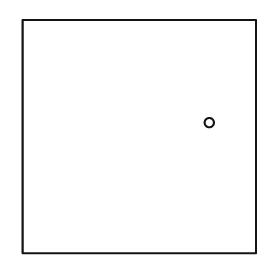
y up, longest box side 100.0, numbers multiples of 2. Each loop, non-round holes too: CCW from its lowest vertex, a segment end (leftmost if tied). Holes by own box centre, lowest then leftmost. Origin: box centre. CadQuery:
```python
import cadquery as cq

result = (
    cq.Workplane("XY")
    .moveTo(-50.0, -50.0)
    .lineTo(50.0, -50.0)
    .lineTo(50.0, 50.0)
    .lineTo(-50.0, 50.0)
    .close()
    .moveTo(30.0, 6.0)
    .circle(2.0)
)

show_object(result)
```